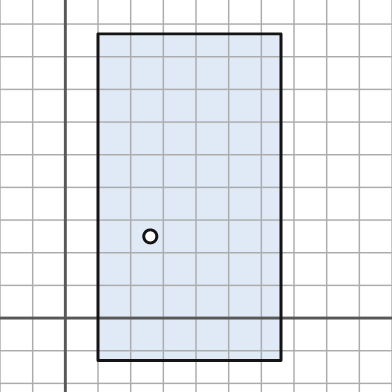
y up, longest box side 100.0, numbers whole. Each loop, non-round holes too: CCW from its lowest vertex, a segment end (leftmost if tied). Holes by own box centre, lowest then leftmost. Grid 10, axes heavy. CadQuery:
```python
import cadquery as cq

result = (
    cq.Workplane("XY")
    .moveTo(10.0, -13.0)
    .lineTo(66.0, -13.0)
    .lineTo(66.0, 87.0)
    .lineTo(10.0, 87.0)
    .close()
    .moveTo(26.0, 25.0)
    .circle(2.0)
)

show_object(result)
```